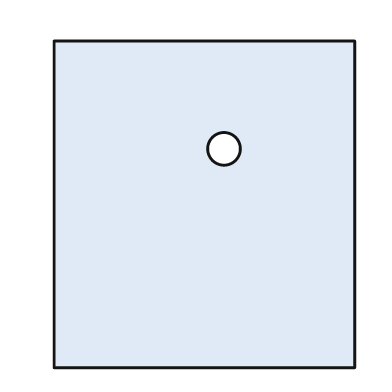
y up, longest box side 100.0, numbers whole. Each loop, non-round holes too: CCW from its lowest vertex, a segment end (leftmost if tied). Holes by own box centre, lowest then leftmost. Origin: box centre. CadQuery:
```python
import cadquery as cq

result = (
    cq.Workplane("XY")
    .moveTo(-46.0, -50.0)
    .lineTo(46.0, -50.0)
    .lineTo(46.0, 50.0)
    .lineTo(-46.0, 50.0)
    .close()
    .moveTo(6.0, 17.0)
    .circle(5.0)
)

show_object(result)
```